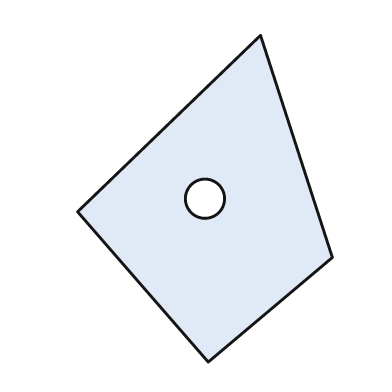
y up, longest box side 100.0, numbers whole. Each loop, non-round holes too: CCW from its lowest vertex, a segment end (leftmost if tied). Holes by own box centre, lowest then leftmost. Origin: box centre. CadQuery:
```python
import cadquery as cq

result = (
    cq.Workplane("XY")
    .moveTo(1.0, -50.0)
    .lineTo(39.0, -18.0)
    .lineTo(17.0, 50.0)
    .lineTo(-39.0, -4.0)
    .close()
    .moveTo(0.0, 0.0)
    .circle(6.0)
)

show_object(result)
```